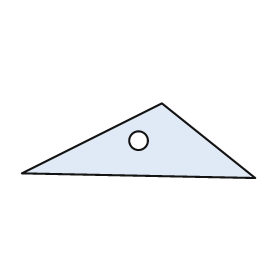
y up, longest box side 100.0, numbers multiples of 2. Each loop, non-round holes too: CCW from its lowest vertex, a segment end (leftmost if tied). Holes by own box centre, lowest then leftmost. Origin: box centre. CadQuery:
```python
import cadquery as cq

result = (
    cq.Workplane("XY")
    .moveTo(50.0, -16.0)
    .lineTo(10.0, 16.0)
    .lineTo(-50.0, -14.0)
    .close()
    .moveTo(0.0, 0.0)
    .circle(4.0)
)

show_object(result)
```